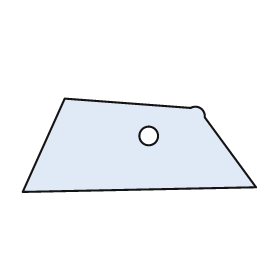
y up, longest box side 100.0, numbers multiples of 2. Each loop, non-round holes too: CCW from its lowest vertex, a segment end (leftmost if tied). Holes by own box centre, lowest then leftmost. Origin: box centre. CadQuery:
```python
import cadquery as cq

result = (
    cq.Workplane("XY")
    .moveTo(-50.0, -20.0)
    .lineTo(50.0, -18.0)
    .lineTo(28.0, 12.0)
    .threePointArc((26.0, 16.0), (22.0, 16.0))
    .lineTo(-32.0, 20.0)
    .close()
    .moveTo(4.0, 4.0)
    .circle(4.0)
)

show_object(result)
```